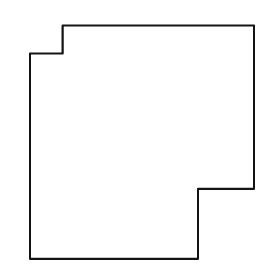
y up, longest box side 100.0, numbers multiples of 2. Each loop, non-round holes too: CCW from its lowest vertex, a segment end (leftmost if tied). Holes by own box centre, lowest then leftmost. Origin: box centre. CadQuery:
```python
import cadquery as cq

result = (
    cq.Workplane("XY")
    .moveTo(-48.0, -50.0)
    .lineTo(24.0, -50.0)
    .lineTo(24.0, -20.0)
    .lineTo(48.0, -20.0)
    .lineTo(48.0, 50.0)
    .lineTo(-34.0, 50.0)
    .lineTo(-34.0, 38.0)
    .lineTo(-48.0, 38.0)
    .close()
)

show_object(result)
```